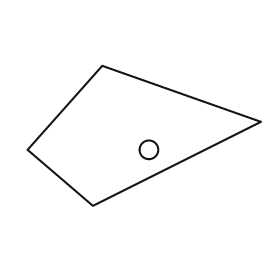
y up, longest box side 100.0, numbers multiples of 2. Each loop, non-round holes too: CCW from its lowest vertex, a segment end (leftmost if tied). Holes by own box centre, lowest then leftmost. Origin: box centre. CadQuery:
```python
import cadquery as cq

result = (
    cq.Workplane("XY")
    .moveTo(-22.0, -30.0)
    .lineTo(50.0, 6.0)
    .lineTo(-18.0, 30.0)
    .lineTo(-50.0, -6.0)
    .close()
    .moveTo(2.0, -6.0)
    .circle(4.0)
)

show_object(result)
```